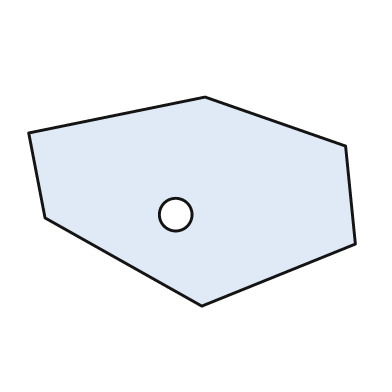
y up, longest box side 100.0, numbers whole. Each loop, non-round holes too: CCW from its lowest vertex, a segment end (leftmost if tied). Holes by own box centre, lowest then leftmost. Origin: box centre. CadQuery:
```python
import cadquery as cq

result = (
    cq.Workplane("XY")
    .moveTo(3.0, -32.0)
    .lineTo(50.0, -13.0)
    .lineTo(47.0, 17.0)
    .lineTo(4.0, 32.0)
    .lineTo(-50.0, 21.0)
    .lineTo(-45.0, -5.0)
    .close()
    .moveTo(-5.0, -4.0)
    .circle(5.0)
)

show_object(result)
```